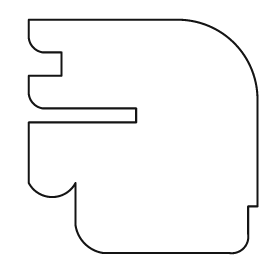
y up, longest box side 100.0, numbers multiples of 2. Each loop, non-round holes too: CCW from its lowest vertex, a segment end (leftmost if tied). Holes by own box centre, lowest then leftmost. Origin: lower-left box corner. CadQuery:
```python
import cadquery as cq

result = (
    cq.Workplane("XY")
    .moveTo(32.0, 0.0)
    .lineTo(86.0, 0.0)
    .threePointArc((92.0, 2.0), (94.0, 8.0))
    .lineTo(94.0, 20.0)
    .lineTo(98.0, 20.0)
    .lineTo(98.0, 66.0)
    .threePointArc((88.0, 90.0), (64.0, 100.0))
    .lineTo(0.0, 100.0)
    .lineTo(0.0, 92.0)
    .threePointArc((2.0, 88.0), (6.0, 86.0))
    .lineTo(14.0, 86.0)
    .lineTo(14.0, 76.0)
    .lineTo(0.0, 76.0)
    .lineTo(0.0, 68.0)
    .threePointArc((2.0, 64.0), (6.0, 62.0))
    .lineTo(46.0, 62.0)
    .lineTo(46.0, 56.0)
    .lineTo(0.0, 56.0)
    .lineTo(0.0, 30.0)
    .threePointArc((10.0, 24.0), (20.0, 30.0))
    .lineTo(20.0, 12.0)
    .threePointArc((24.0, 4.0), (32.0, 0.0))
    .close()
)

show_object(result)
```